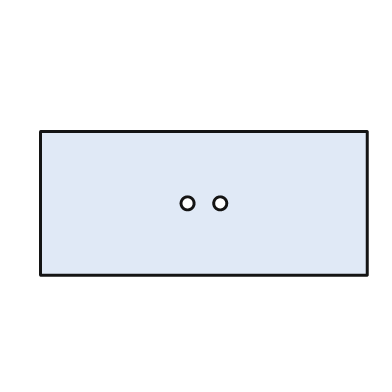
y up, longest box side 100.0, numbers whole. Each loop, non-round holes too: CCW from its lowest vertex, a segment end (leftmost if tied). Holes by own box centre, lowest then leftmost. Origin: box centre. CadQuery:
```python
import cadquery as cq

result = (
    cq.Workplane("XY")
    .moveTo(-50.0, -22.0)
    .lineTo(50.0, -22.0)
    .lineTo(50.0, 22.0)
    .lineTo(-50.0, 22.0)
    .close()
    .moveTo(-5.0, 0.0)
    .circle(2.0)
    .moveTo(5.0, 0.0)
    .circle(2.0)
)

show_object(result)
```